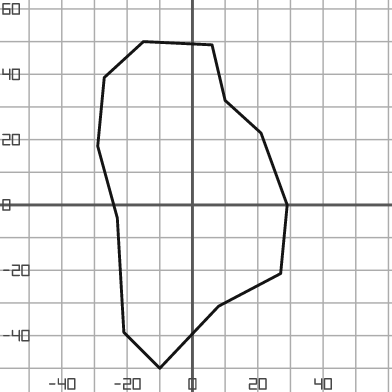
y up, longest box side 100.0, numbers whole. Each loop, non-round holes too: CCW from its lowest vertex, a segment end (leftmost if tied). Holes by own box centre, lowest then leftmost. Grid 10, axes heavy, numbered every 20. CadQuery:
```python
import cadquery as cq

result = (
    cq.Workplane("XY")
    .moveTo(-10.0, -50.0)
    .lineTo(8.0, -31.0)
    .lineTo(27.0, -21.0)
    .lineTo(29.0, 0.0)
    .lineTo(21.0, 22.0)
    .lineTo(10.0, 32.0)
    .lineTo(6.0, 49.0)
    .lineTo(-15.0, 50.0)
    .lineTo(-27.0, 39.0)
    .lineTo(-29.0, 18.0)
    .lineTo(-23.0, -4.0)
    .lineTo(-21.0, -39.0)
    .close()
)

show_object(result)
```